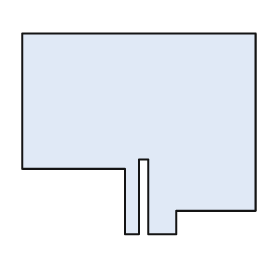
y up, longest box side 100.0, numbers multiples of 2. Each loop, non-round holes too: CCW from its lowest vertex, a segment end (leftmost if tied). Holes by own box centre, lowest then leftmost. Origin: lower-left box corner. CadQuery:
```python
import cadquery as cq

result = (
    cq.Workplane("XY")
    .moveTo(44.0, 0.0)
    .lineTo(50.0, 0.0)
    .lineTo(50.0, 32.0)
    .lineTo(54.0, 32.0)
    .lineTo(54.0, 0.0)
    .lineTo(66.0, 0.0)
    .lineTo(66.0, 10.0)
    .lineTo(100.0, 10.0)
    .lineTo(100.0, 86.0)
    .lineTo(0.0, 86.0)
    .lineTo(0.0, 28.0)
    .lineTo(44.0, 28.0)
    .close()
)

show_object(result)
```